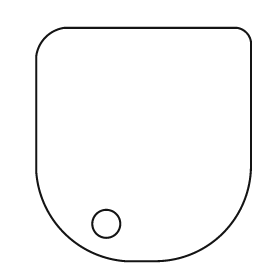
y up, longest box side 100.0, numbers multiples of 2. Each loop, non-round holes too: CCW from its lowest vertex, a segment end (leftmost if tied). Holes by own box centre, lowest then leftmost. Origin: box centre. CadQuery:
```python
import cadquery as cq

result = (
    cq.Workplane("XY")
    .moveTo(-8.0, -50.0)
    .lineTo(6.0, -50.0)
    .threePointArc((34.0, -38.0), (46.0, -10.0))
    .lineTo(46.0, 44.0)
    .threePointArc((44.0, 48.0), (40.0, 50.0))
    .lineTo(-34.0, 50.0)
    .threePointArc((-42.0, 46.0), (-46.0, 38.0))
    .lineTo(-46.0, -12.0)
    .threePointArc((-34.0, -38.0), (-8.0, -50.0))
    .close()
    .moveTo(-16.0, -34.0)
    .circle(6.0)
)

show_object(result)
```